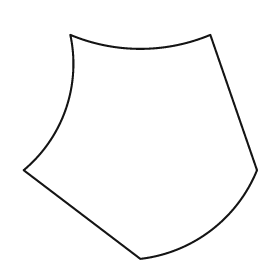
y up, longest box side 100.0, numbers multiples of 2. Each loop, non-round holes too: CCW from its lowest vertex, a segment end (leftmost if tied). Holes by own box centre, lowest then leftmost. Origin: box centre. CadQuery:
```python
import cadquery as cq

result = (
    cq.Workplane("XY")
    .moveTo(0.0, -48.0)
    .threePointArc((30.0, -36.0), (50.0, -10.0))
    .lineTo(30.0, 48.0)
    .threePointArc((0.0, 42.0), (-30.0, 48.0))
    .threePointArc((-32.0, 16.0), (-50.0, -10.0))
    .close()
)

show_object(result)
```